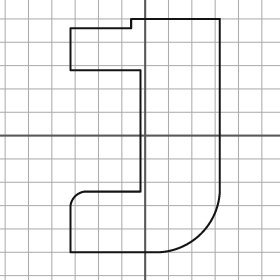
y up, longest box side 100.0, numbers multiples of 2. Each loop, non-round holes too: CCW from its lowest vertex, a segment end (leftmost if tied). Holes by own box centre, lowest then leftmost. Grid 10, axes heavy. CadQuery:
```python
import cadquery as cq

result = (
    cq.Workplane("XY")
    .moveTo(-32.0, -50.0)
    .lineTo(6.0, -50.0)
    .threePointArc((24.0, -42.0), (32.0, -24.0))
    .lineTo(32.0, 50.0)
    .lineTo(-6.0, 50.0)
    .lineTo(-6.0, 46.0)
    .lineTo(-32.0, 46.0)
    .lineTo(-32.0, 28.0)
    .lineTo(-2.0, 28.0)
    .lineTo(-2.0, -24.0)
    .lineTo(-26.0, -24.0)
    .threePointArc((-30.0, -26.0), (-32.0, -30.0))
    .close()
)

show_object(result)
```